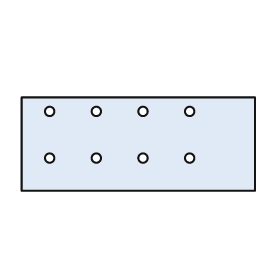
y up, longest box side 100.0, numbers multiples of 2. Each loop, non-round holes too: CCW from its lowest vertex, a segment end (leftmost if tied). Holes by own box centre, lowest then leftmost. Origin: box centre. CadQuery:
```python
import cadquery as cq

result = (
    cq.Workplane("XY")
    .moveTo(-50.0, -20.0)
    .lineTo(50.0, -20.0)
    .lineTo(50.0, 20.0)
    .lineTo(-50.0, 20.0)
    .close()
    .moveTo(-38.0, -6.0)
    .circle(2.0)
    .moveTo(-18.0, -6.0)
    .circle(2.0)
    .moveTo(2.0, -6.0)
    .circle(2.0)
    .moveTo(22.0, -6.0)
    .circle(2.0)
    .moveTo(-38.0, 14.0)
    .circle(2.0)
    .moveTo(-18.0, 14.0)
    .circle(2.0)
    .moveTo(2.0, 14.0)
    .circle(2.0)
    .moveTo(22.0, 14.0)
    .circle(2.0)
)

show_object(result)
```